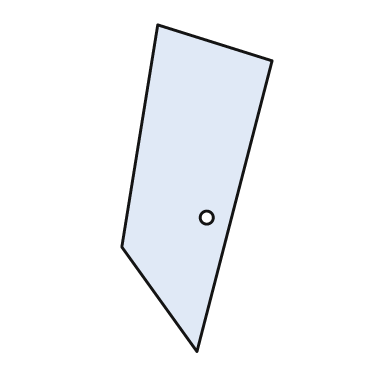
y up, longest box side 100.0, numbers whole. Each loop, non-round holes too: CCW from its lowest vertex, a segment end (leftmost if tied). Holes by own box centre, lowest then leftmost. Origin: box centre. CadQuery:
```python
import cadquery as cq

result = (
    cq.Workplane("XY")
    .moveTo(0.0, -50.0)
    .lineTo(23.0, 39.0)
    .lineTo(-12.0, 50.0)
    .lineTo(-23.0, -18.0)
    .close()
    .moveTo(3.0, -9.0)
    .circle(2.0)
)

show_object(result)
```